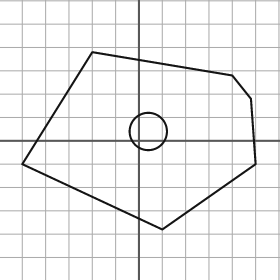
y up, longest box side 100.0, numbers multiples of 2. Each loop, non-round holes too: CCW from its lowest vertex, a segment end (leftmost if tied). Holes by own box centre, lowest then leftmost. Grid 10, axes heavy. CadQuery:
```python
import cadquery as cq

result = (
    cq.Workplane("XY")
    .moveTo(10.0, -38.0)
    .lineTo(50.0, -10.0)
    .lineTo(48.0, 18.0)
    .lineTo(40.0, 28.0)
    .lineTo(-20.0, 38.0)
    .lineTo(-50.0, -10.0)
    .close()
    .moveTo(4.0, 4.0)
    .circle(8.0)
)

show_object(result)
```